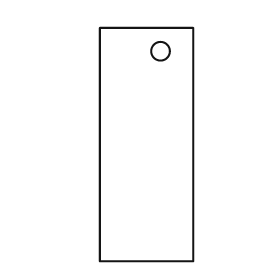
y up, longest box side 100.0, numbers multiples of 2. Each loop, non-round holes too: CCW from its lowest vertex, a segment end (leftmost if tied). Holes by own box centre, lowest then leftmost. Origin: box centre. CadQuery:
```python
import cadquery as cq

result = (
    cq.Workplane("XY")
    .moveTo(-20.0, -50.0)
    .lineTo(20.0, -50.0)
    .lineTo(20.0, 50.0)
    .lineTo(-20.0, 50.0)
    .close()
    .moveTo(6.0, 40.0)
    .circle(4.0)
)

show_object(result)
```